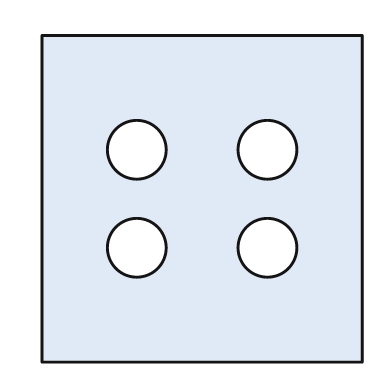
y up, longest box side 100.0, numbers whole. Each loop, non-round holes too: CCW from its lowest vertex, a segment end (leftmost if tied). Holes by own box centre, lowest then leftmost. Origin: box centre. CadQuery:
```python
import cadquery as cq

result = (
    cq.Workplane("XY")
    .moveTo(-49.0, -50.0)
    .lineTo(49.0, -50.0)
    .lineTo(49.0, 50.0)
    .lineTo(-49.0, 50.0)
    .close()
    .moveTo(-20.0, -15.0)
    .circle(9.0)
    .moveTo(20.0, -15.0)
    .circle(9.0)
    .moveTo(-20.0, 15.0)
    .circle(9.0)
    .moveTo(20.0, 15.0)
    .circle(9.0)
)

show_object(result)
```